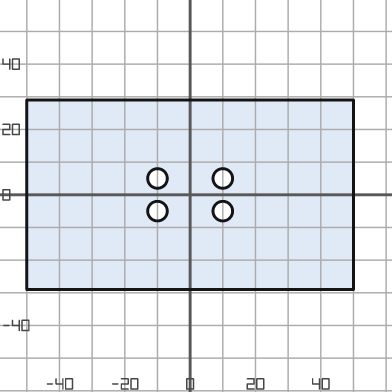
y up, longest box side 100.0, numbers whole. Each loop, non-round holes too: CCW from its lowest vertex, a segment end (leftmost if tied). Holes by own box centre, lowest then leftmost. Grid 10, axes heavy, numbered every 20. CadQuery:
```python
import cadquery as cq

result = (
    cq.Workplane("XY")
    .moveTo(-50.0, -29.0)
    .lineTo(50.0, -29.0)
    .lineTo(50.0, 29.0)
    .lineTo(-50.0, 29.0)
    .close()
    .moveTo(-10.0, -5.0)
    .circle(3.0)
    .moveTo(10.0, -5.0)
    .circle(3.0)
    .moveTo(-10.0, 5.0)
    .circle(3.0)
    .moveTo(10.0, 5.0)
    .circle(3.0)
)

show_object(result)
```